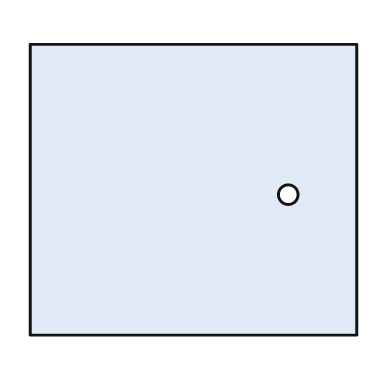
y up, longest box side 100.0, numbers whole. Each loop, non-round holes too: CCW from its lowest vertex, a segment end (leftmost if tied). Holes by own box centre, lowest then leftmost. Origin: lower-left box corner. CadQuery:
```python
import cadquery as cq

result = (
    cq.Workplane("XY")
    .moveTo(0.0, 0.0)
    .lineTo(100.0, 0.0)
    .lineTo(100.0, 89.0)
    .lineTo(0.0, 89.0)
    .close()
    .moveTo(79.0, 43.0)
    .circle(3.0)
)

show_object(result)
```